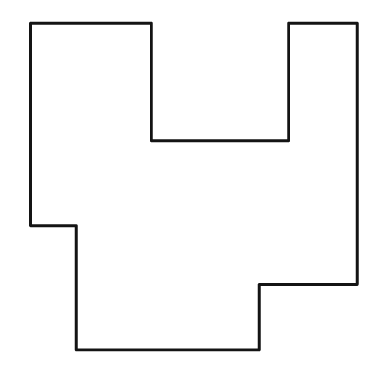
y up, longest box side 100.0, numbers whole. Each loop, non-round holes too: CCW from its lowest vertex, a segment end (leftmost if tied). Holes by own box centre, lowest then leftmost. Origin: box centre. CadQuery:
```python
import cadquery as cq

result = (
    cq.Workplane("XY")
    .moveTo(-36.0, -50.0)
    .lineTo(20.0, -50.0)
    .lineTo(20.0, -30.0)
    .lineTo(50.0, -30.0)
    .lineTo(50.0, 50.0)
    .lineTo(29.0, 50.0)
    .lineTo(29.0, 14.0)
    .lineTo(-13.0, 14.0)
    .lineTo(-13.0, 50.0)
    .lineTo(-50.0, 50.0)
    .lineTo(-50.0, -12.0)
    .lineTo(-36.0, -12.0)
    .close()
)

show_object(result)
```